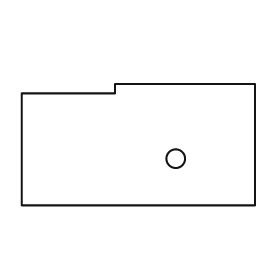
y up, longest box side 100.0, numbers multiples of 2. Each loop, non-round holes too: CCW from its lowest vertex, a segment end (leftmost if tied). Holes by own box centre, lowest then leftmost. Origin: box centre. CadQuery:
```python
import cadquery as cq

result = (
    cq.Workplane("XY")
    .moveTo(-50.0, -26.0)
    .lineTo(50.0, -26.0)
    .lineTo(50.0, 26.0)
    .lineTo(-10.0, 26.0)
    .lineTo(-10.0, 22.0)
    .lineTo(-50.0, 22.0)
    .close()
    .moveTo(16.0, -6.0)
    .circle(4.0)
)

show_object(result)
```